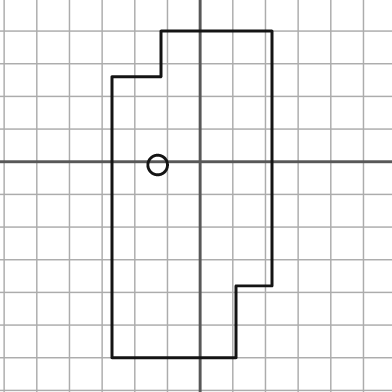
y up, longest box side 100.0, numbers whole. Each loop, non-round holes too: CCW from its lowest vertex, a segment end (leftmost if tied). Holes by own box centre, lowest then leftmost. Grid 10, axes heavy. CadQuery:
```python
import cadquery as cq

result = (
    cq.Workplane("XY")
    .moveTo(-27.0, -60.0)
    .lineTo(11.0, -60.0)
    .lineTo(11.0, -38.0)
    .lineTo(22.0, -38.0)
    .lineTo(22.0, 40.0)
    .lineTo(-12.0, 40.0)
    .lineTo(-12.0, 26.0)
    .lineTo(-27.0, 26.0)
    .close()
    .moveTo(-13.0, -1.0)
    .circle(3.0)
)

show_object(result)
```